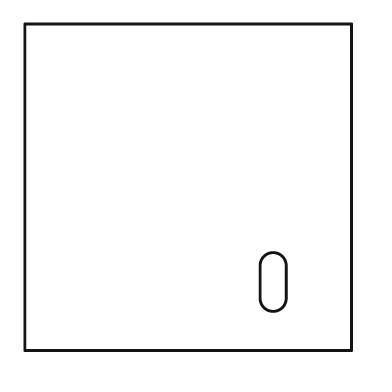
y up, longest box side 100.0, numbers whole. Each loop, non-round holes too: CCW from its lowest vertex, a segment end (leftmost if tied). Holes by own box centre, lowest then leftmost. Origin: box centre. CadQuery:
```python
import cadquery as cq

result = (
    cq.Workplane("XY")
    .moveTo(-50.0, -50.0)
    .lineTo(50.0, -50.0)
    .lineTo(50.0, 50.0)
    .lineTo(-50.0, 50.0)
    .close()
    .moveTo(22.0, -34.0)
    .threePointArc((26.0, -38.0), (30.0, -34.0))
    .lineTo(30.0, -24.0)
    .threePointArc((26.0, -20.0), (22.0, -24.0))
    .close()
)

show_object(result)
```